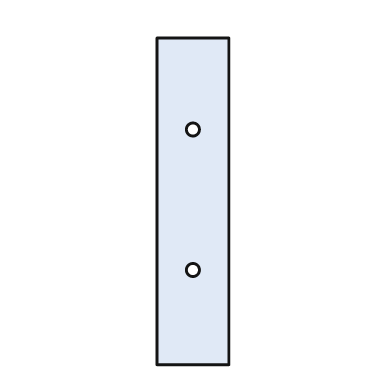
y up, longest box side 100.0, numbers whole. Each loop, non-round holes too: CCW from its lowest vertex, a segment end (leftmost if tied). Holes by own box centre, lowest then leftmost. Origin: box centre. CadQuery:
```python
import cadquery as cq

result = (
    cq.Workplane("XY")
    .moveTo(-11.0, -50.0)
    .lineTo(11.0, -50.0)
    .lineTo(11.0, 50.0)
    .lineTo(-11.0, 50.0)
    .close()
    .moveTo(0.0, -21.0)
    .circle(2.0)
    .moveTo(0.0, 22.0)
    .circle(2.0)
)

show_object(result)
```